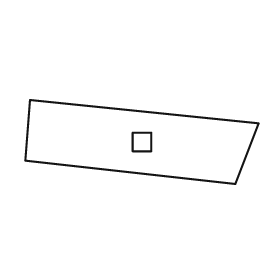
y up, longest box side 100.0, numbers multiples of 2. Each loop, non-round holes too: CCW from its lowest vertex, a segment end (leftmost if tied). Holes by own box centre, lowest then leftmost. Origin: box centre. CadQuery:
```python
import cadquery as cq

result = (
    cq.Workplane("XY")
    .moveTo(40.0, -18.0)
    .lineTo(50.0, 8.0)
    .lineTo(-48.0, 18.0)
    .lineTo(-50.0, -8.0)
    .close()
    .moveTo(-4.0, -4.0)
    .lineTo(4.0, -4.0)
    .lineTo(4.0, 4.0)
    .lineTo(-4.0, 4.0)
    .close()
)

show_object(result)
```